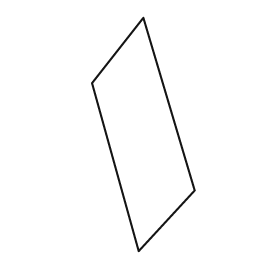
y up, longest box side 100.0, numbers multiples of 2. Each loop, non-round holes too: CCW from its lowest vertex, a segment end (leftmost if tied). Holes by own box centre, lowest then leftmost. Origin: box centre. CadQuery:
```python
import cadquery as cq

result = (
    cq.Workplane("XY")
    .moveTo(-2.0, -50.0)
    .lineTo(22.0, -24.0)
    .lineTo(0.0, 50.0)
    .lineTo(-22.0, 22.0)
    .close()
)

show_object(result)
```